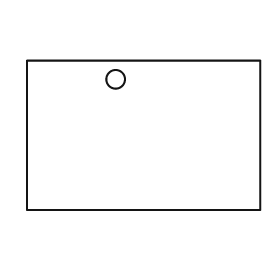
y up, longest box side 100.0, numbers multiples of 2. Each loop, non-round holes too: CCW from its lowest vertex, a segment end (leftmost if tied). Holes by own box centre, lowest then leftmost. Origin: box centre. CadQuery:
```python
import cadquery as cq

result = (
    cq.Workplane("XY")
    .moveTo(-50.0, -32.0)
    .lineTo(50.0, -32.0)
    .lineTo(50.0, 32.0)
    .lineTo(-50.0, 32.0)
    .close()
    .moveTo(-12.0, 24.0)
    .circle(4.0)
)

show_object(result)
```